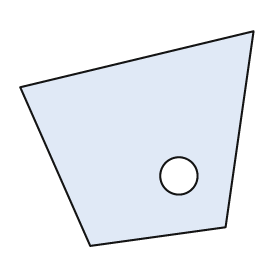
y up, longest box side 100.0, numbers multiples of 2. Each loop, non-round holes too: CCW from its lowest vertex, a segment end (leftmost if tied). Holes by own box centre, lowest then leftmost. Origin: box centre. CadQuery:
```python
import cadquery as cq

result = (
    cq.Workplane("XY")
    .moveTo(-20.0, -46.0)
    .lineTo(38.0, -38.0)
    .lineTo(50.0, 46.0)
    .lineTo(-50.0, 22.0)
    .close()
    .moveTo(18.0, -16.0)
    .circle(8.0)
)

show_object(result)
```